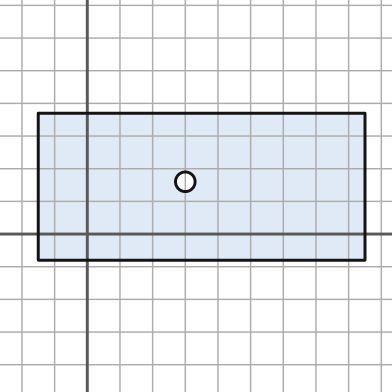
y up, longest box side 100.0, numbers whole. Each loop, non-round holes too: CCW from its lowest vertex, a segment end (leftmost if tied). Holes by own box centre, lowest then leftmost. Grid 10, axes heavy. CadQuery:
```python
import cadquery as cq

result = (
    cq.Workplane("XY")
    .moveTo(-15.0, -8.0)
    .lineTo(85.0, -8.0)
    .lineTo(85.0, 37.0)
    .lineTo(-15.0, 37.0)
    .close()
    .moveTo(30.0, 16.0)
    .circle(3.0)
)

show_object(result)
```